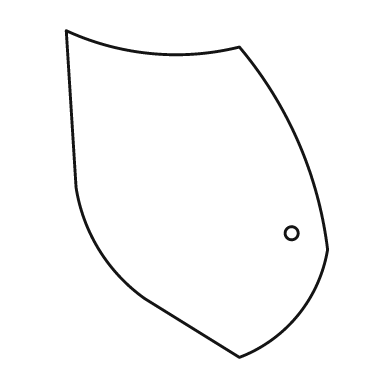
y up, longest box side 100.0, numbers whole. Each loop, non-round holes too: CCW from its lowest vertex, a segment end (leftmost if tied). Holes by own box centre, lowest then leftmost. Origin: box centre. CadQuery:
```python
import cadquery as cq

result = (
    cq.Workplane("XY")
    .moveTo(13.0, -50.0)
    .threePointArc((31.0, -37.0), (40.0, -17.0))
    .threePointArc((31.0, 16.0), (13.0, 45.0))
    .threePointArc((-14.0, 43.0), (-40.0, 50.0))
    .lineTo(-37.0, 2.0)
    .threePointArc((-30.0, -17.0), (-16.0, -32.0))
    .close()
    .moveTo(29.0, -12.0)
    .circle(2.0)
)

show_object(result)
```